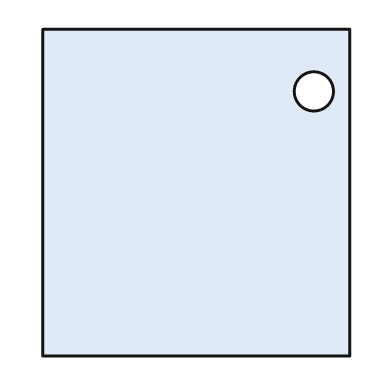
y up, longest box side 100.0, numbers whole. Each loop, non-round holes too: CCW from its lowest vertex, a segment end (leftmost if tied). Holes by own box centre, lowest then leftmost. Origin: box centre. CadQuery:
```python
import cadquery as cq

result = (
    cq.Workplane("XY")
    .moveTo(-47.0, -50.0)
    .lineTo(47.0, -50.0)
    .lineTo(47.0, 50.0)
    .lineTo(-47.0, 50.0)
    .close()
    .moveTo(36.0, 31.0)
    .circle(6.0)
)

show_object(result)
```